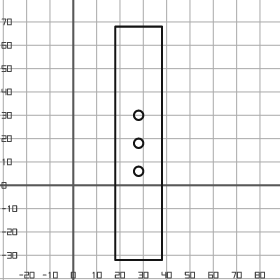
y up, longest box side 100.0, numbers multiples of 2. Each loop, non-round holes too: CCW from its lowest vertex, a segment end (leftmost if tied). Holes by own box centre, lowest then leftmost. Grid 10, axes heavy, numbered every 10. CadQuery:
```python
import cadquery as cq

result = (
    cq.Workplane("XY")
    .moveTo(18.0, -32.0)
    .lineTo(38.0, -32.0)
    .lineTo(38.0, 68.0)
    .lineTo(18.0, 68.0)
    .close()
    .moveTo(28.0, 6.0)
    .circle(2.0)
    .moveTo(28.0, 18.0)
    .circle(2.0)
    .moveTo(28.0, 30.0)
    .circle(2.0)
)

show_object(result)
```